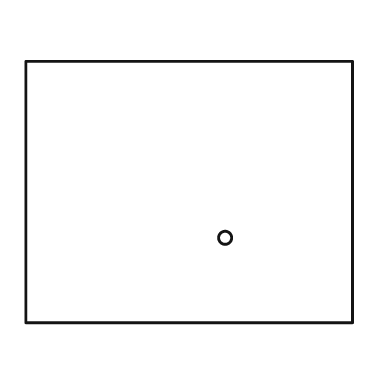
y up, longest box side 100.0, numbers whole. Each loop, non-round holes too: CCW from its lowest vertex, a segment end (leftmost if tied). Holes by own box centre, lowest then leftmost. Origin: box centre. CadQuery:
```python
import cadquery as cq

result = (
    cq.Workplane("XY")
    .moveTo(-50.0, -40.0)
    .lineTo(50.0, -40.0)
    .lineTo(50.0, 40.0)
    .lineTo(-50.0, 40.0)
    .close()
    .moveTo(11.0, -14.0)
    .circle(2.0)
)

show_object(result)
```